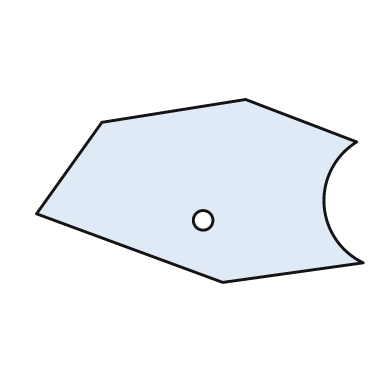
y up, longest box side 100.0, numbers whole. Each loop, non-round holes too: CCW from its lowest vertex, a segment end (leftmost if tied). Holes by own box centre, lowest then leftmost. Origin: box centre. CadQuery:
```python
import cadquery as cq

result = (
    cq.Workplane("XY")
    .moveTo(7.0, -28.0)
    .lineTo(50.0, -22.0)
    .threePointArc((38.0, -4.0), (48.0, 15.0))
    .lineTo(14.0, 28.0)
    .lineTo(-30.0, 21.0)
    .lineTo(-50.0, -7.0)
    .close()
    .moveTo(1.0, -9.0)
    .circle(3.0)
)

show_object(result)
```